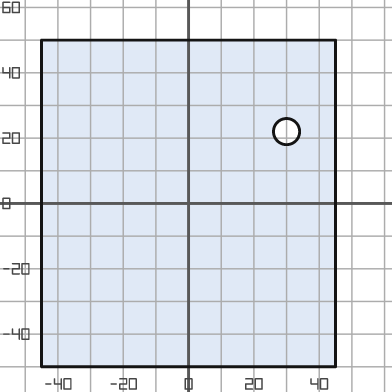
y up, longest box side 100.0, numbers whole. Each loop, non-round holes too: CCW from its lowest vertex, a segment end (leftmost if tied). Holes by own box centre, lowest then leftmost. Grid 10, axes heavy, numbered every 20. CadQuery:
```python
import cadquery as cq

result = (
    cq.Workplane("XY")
    .moveTo(-45.0, -50.0)
    .lineTo(45.0, -50.0)
    .lineTo(45.0, 50.0)
    .lineTo(-45.0, 50.0)
    .close()
    .moveTo(30.0, 22.0)
    .circle(4.0)
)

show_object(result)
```